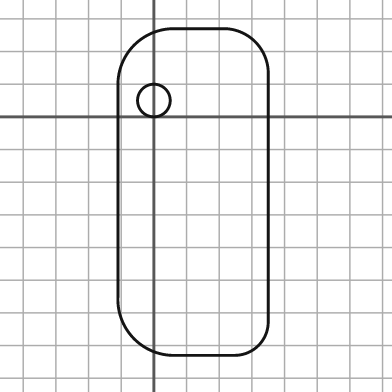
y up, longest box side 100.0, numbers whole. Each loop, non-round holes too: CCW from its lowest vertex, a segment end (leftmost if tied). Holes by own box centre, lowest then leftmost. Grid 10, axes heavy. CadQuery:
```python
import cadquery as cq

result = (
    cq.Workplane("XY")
    .moveTo(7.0, -73.0)
    .lineTo(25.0, -73.0)
    .threePointArc((32.0, -70.0), (35.0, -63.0))
    .lineTo(35.0, 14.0)
    .threePointArc((31.0, 23.0), (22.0, 27.0))
    .lineTo(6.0, 27.0)
    .threePointArc((-6.0, 22.0), (-11.0, 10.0))
    .lineTo(-11.0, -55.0)
    .threePointArc((-6.0, -68.0), (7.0, -73.0))
    .close()
    .moveTo(0.0, 5.0)
    .circle(5.0)
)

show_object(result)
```